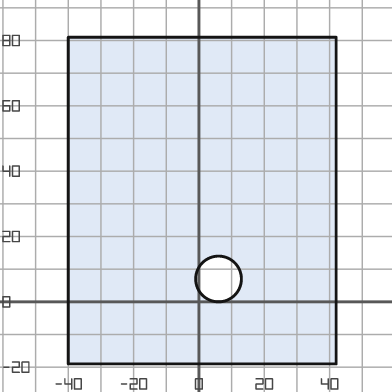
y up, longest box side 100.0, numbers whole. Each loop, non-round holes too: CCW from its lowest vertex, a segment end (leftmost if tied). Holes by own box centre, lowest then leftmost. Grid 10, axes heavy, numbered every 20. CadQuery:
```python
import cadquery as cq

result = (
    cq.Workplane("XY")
    .moveTo(-40.0, -19.0)
    .lineTo(42.0, -19.0)
    .lineTo(42.0, 81.0)
    .lineTo(-40.0, 81.0)
    .close()
    .moveTo(6.0, 7.0)
    .circle(7.0)
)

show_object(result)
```